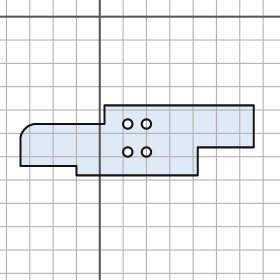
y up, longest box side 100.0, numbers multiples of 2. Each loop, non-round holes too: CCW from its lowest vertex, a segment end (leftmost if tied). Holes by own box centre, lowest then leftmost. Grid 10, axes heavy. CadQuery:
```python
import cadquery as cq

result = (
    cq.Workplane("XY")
    .moveTo(-10.0, -68.0)
    .lineTo(42.0, -68.0)
    .lineTo(42.0, -56.0)
    .lineTo(66.0, -56.0)
    .lineTo(66.0, -38.0)
    .lineTo(2.0, -38.0)
    .lineTo(2.0, -46.0)
    .lineTo(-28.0, -46.0)
    .threePointArc((-32.0, -48.0), (-34.0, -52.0))
    .lineTo(-34.0, -64.0)
    .lineTo(-10.0, -64.0)
    .close()
    .moveTo(12.0, -58.0)
    .circle(2.0)
    .moveTo(20.0, -58.0)
    .circle(2.0)
    .moveTo(12.0, -46.0)
    .circle(2.0)
    .moveTo(20.0, -46.0)
    .circle(2.0)
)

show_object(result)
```